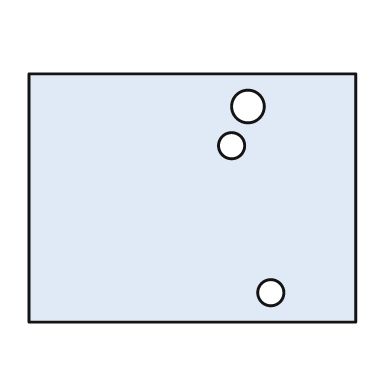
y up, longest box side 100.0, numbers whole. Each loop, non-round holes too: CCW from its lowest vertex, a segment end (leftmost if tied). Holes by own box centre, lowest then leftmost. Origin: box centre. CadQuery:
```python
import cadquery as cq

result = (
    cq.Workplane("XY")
    .moveTo(-50.0, -38.0)
    .lineTo(50.0, -38.0)
    .lineTo(50.0, 38.0)
    .lineTo(-50.0, 38.0)
    .close()
    .moveTo(24.0, -29.0)
    .circle(4.0)
    .moveTo(12.0, 16.0)
    .circle(4.0)
    .moveTo(17.0, 28.0)
    .circle(5.0)
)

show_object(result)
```